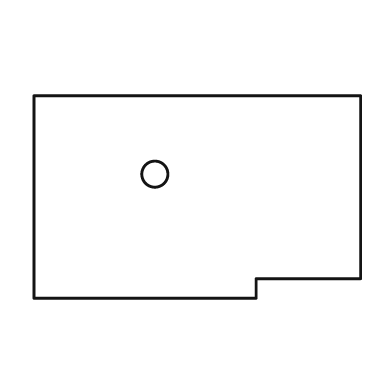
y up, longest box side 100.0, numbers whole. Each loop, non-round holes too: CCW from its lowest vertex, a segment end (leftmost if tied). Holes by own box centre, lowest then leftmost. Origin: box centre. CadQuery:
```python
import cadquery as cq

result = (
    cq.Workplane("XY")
    .moveTo(-50.0, -31.0)
    .lineTo(18.0, -31.0)
    .lineTo(18.0, -25.0)
    .lineTo(50.0, -25.0)
    .lineTo(50.0, 31.0)
    .lineTo(-50.0, 31.0)
    .close()
    .moveTo(-13.0, 7.0)
    .circle(4.0)
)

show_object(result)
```